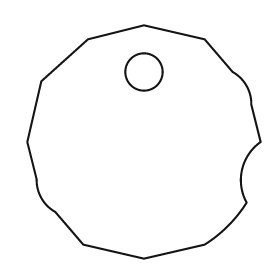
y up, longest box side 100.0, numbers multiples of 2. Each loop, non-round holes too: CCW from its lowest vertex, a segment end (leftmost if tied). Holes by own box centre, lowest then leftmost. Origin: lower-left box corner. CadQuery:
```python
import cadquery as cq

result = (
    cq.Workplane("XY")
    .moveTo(50.0, 0.0)
    .lineTo(76.0, 6.0)
    .threePointArc((86.0, 14.0), (94.0, 24.0))
    .threePointArc((92.0, 38.0), (100.0, 50.0))
    .lineTo(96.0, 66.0)
    .threePointArc((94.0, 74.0), (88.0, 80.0))
    .lineTo(76.0, 94.0)
    .lineTo(50.0, 100.0)
    .lineTo(26.0, 94.0)
    .lineTo(6.0, 76.0)
    .lineTo(0.0, 50.0)
    .lineTo(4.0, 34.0)
    .threePointArc((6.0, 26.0), (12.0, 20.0))
    .lineTo(24.0, 6.0)
    .close()
    .moveTo(50.0, 80.0)
    .circle(8.0)
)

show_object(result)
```